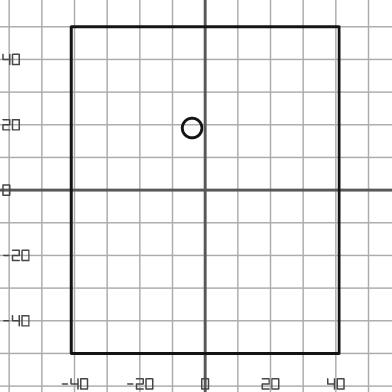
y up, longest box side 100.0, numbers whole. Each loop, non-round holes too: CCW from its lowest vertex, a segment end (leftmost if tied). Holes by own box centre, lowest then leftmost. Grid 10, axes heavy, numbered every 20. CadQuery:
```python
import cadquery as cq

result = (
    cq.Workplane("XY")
    .moveTo(-41.0, -50.0)
    .lineTo(41.0, -50.0)
    .lineTo(41.0, 50.0)
    .lineTo(-41.0, 50.0)
    .close()
    .moveTo(-4.0, 19.0)
    .circle(3.0)
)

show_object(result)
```